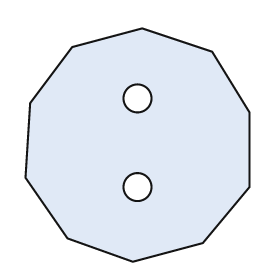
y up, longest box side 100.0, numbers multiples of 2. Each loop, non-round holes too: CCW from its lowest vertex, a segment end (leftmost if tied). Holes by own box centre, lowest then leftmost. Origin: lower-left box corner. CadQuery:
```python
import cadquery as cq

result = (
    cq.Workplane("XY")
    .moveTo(46.0, 0.0)
    .lineTo(76.0, 8.0)
    .lineTo(96.0, 32.0)
    .lineTo(96.0, 64.0)
    .lineTo(80.0, 90.0)
    .lineTo(50.0, 100.0)
    .lineTo(20.0, 92.0)
    .lineTo(2.0, 68.0)
    .lineTo(0.0, 36.0)
    .lineTo(18.0, 10.0)
    .close()
    .moveTo(48.0, 32.0)
    .circle(6.0)
    .moveTo(48.0, 70.0)
    .circle(6.0)
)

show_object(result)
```